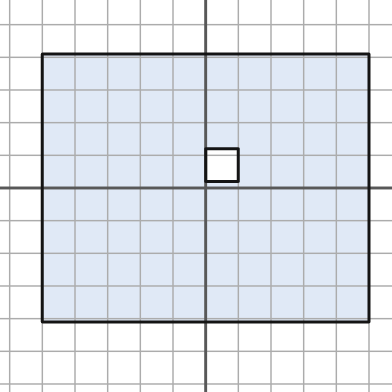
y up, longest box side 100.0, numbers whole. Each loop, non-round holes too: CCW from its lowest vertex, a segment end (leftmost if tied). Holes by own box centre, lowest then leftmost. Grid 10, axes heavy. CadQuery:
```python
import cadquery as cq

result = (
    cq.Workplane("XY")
    .moveTo(-50.0, -41.0)
    .lineTo(50.0, -41.0)
    .lineTo(50.0, 41.0)
    .lineTo(-50.0, 41.0)
    .close()
    .moveTo(0.0, 2.0)
    .lineTo(10.0, 2.0)
    .lineTo(10.0, 12.0)
    .lineTo(0.0, 12.0)
    .close()
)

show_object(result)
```